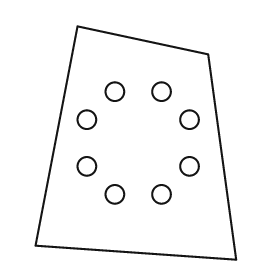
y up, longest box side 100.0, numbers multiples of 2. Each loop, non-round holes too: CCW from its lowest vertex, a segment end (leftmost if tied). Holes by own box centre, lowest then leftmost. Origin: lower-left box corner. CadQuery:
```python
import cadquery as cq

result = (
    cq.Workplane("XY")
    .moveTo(86.0, 0.0)
    .lineTo(74.0, 88.0)
    .lineTo(18.0, 100.0)
    .lineTo(0.0, 6.0)
    .close()
    .moveTo(34.0, 28.0)
    .circle(4.0)
    .moveTo(54.0, 28.0)
    .circle(4.0)
    .moveTo(22.0, 40.0)
    .circle(4.0)
    .moveTo(66.0, 40.0)
    .circle(4.0)
    .moveTo(22.0, 60.0)
    .circle(4.0)
    .moveTo(66.0, 60.0)
    .circle(4.0)
    .moveTo(34.0, 72.0)
    .circle(4.0)
    .moveTo(54.0, 72.0)
    .circle(4.0)
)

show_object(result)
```